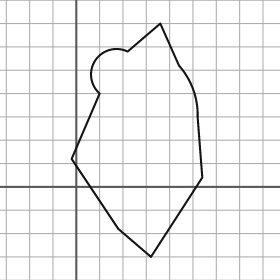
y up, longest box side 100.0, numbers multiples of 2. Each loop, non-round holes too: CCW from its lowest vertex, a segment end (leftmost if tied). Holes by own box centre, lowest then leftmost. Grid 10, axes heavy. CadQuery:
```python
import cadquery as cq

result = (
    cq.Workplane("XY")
    .moveTo(32.0, -30.0)
    .lineTo(54.0, 4.0)
    .lineTo(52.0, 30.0)
    .threePointArc((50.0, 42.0), (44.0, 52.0))
    .lineTo(36.0, 70.0)
    .lineTo(22.0, 58.0)
    .threePointArc((8.0, 54.0), (10.0, 40.0))
    .lineTo(-2.0, 12.0)
    .lineTo(18.0, -18.0)
    .close()
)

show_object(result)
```